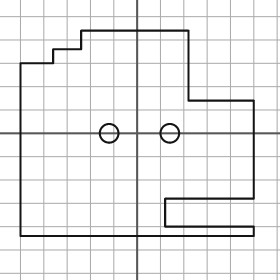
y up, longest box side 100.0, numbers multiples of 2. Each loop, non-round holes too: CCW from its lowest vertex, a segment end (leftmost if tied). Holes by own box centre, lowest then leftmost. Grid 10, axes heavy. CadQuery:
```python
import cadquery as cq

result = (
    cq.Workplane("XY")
    .moveTo(-50.0, -44.0)
    .lineTo(50.0, -44.0)
    .lineTo(50.0, -40.0)
    .lineTo(12.0, -40.0)
    .lineTo(12.0, -28.0)
    .lineTo(50.0, -28.0)
    .lineTo(50.0, 14.0)
    .lineTo(22.0, 14.0)
    .lineTo(22.0, 44.0)
    .lineTo(-24.0, 44.0)
    .lineTo(-24.0, 36.0)
    .lineTo(-36.0, 36.0)
    .lineTo(-36.0, 30.0)
    .lineTo(-50.0, 30.0)
    .close()
    .moveTo(-12.0, 0.0)
    .circle(4.0)
    .moveTo(14.0, 0.0)
    .circle(4.0)
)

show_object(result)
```